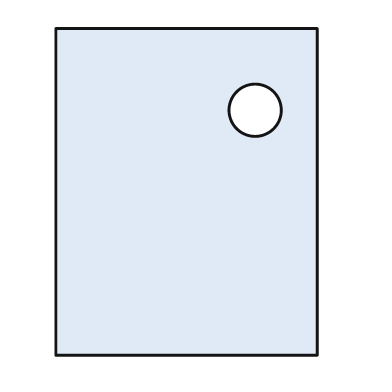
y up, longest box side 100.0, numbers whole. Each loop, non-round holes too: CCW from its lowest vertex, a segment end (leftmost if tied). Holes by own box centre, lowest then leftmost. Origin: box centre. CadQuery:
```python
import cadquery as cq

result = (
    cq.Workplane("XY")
    .moveTo(-40.0, -50.0)
    .lineTo(40.0, -50.0)
    .lineTo(40.0, 50.0)
    .lineTo(-40.0, 50.0)
    .close()
    .moveTo(21.0, 25.0)
    .circle(8.0)
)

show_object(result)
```